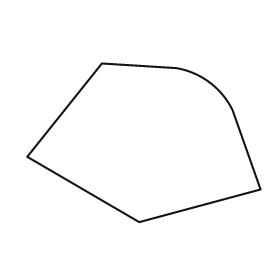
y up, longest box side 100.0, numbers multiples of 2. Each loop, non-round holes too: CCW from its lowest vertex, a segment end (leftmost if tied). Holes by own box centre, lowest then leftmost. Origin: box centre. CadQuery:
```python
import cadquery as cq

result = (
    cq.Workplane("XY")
    .moveTo(-2.0, -34.0)
    .lineTo(50.0, -20.0)
    .lineTo(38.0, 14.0)
    .threePointArc((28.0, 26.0), (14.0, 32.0))
    .lineTo(-18.0, 34.0)
    .lineTo(-50.0, -6.0)
    .close()
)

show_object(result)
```